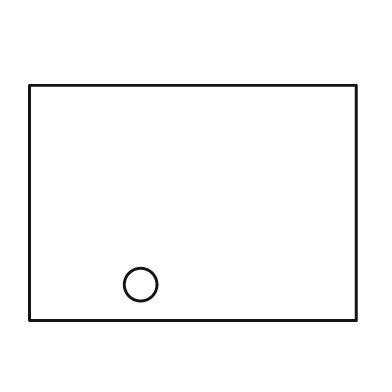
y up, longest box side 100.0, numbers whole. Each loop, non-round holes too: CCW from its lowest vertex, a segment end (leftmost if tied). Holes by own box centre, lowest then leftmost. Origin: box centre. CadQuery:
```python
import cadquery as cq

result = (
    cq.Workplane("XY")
    .moveTo(-50.0, -36.0)
    .lineTo(50.0, -36.0)
    .lineTo(50.0, 36.0)
    .lineTo(-50.0, 36.0)
    .close()
    .moveTo(-16.0, -25.0)
    .circle(5.0)
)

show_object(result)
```